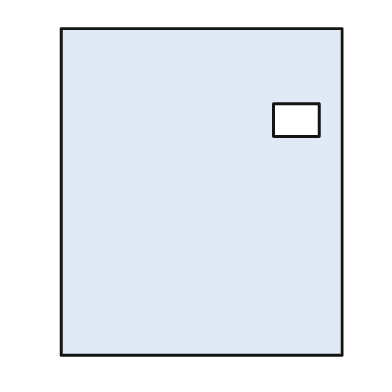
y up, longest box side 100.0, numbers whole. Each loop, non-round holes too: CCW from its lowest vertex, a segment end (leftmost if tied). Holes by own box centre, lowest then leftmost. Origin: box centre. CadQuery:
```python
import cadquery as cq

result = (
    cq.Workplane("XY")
    .moveTo(-43.0, -50.0)
    .lineTo(43.0, -50.0)
    .lineTo(43.0, 50.0)
    .lineTo(-43.0, 50.0)
    .close()
    .moveTo(22.0, 17.0)
    .lineTo(36.0, 17.0)
    .lineTo(36.0, 27.0)
    .lineTo(22.0, 27.0)
    .close()
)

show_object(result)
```